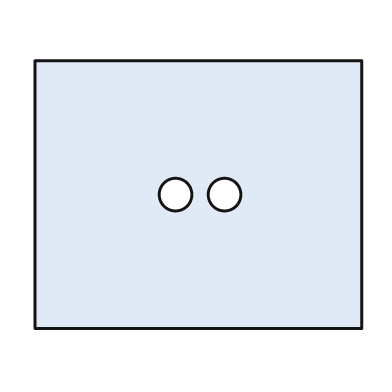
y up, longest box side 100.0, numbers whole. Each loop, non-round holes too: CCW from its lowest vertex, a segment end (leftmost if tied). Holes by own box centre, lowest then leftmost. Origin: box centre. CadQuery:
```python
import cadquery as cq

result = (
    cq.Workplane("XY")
    .moveTo(-50.0, -41.0)
    .lineTo(50.0, -41.0)
    .lineTo(50.0, 41.0)
    .lineTo(-50.0, 41.0)
    .close()
    .moveTo(-7.0, 0.0)
    .circle(5.0)
    .moveTo(8.0, 0.0)
    .circle(5.0)
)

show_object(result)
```